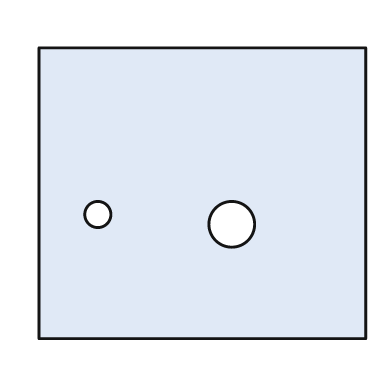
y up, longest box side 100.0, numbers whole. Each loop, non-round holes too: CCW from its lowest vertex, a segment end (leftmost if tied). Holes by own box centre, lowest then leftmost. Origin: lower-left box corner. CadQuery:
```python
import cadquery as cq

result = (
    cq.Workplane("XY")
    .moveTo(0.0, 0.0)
    .lineTo(100.0, 0.0)
    .lineTo(100.0, 89.0)
    .lineTo(0.0, 89.0)
    .close()
    .moveTo(59.0, 35.0)
    .circle(7.0)
    .moveTo(18.0, 38.0)
    .circle(4.0)
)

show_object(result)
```